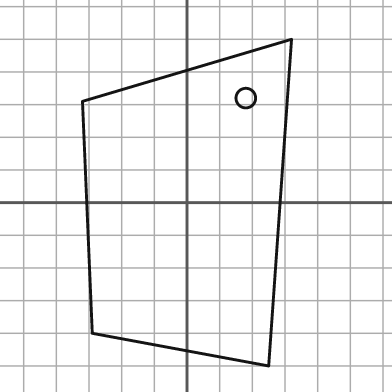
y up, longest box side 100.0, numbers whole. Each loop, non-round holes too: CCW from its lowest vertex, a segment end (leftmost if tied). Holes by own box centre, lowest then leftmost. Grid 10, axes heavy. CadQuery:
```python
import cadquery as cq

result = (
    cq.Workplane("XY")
    .moveTo(25.0, -50.0)
    .lineTo(32.0, 50.0)
    .lineTo(-32.0, 31.0)
    .lineTo(-29.0, -40.0)
    .close()
    .moveTo(18.0, 32.0)
    .circle(3.0)
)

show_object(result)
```